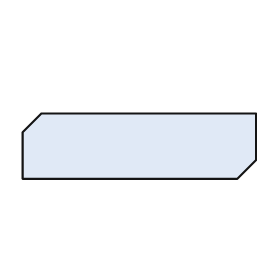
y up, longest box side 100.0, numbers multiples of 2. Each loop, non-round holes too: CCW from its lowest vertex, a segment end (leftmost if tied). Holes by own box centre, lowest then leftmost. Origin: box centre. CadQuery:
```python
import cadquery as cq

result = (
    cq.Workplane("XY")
    .moveTo(-50.0, -14.0)
    .lineTo(42.0, -14.0)
    .lineTo(50.0, -6.0)
    .lineTo(50.0, 14.0)
    .lineTo(-42.0, 14.0)
    .lineTo(-50.0, 6.0)
    .close()
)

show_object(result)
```